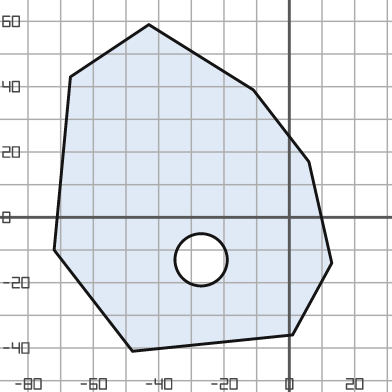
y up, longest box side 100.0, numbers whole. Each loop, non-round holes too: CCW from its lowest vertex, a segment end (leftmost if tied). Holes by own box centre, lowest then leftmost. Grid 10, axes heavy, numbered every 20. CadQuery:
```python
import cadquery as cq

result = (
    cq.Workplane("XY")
    .moveTo(-48.0, -41.0)
    .lineTo(1.0, -36.0)
    .lineTo(13.0, -14.0)
    .lineTo(6.0, 17.0)
    .lineTo(-11.0, 39.0)
    .lineTo(-43.0, 59.0)
    .lineTo(-67.0, 43.0)
    .lineTo(-72.0, -10.0)
    .close()
    .moveTo(-27.0, -13.0)
    .circle(8.0)
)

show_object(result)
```